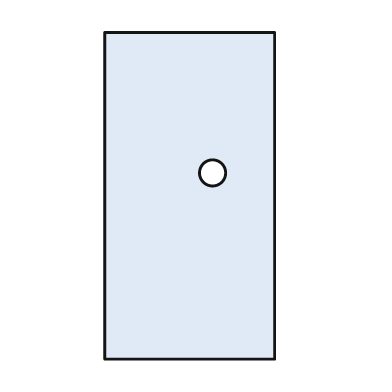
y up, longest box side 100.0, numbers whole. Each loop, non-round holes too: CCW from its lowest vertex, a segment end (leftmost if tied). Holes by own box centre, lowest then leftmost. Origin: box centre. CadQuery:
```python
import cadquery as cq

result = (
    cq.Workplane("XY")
    .moveTo(-26.0, -50.0)
    .lineTo(26.0, -50.0)
    .lineTo(26.0, 50.0)
    .lineTo(-26.0, 50.0)
    .close()
    .moveTo(7.0, 7.0)
    .circle(4.0)
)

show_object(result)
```